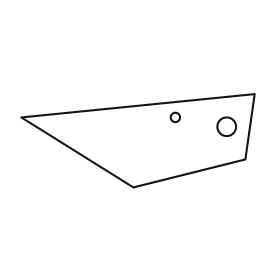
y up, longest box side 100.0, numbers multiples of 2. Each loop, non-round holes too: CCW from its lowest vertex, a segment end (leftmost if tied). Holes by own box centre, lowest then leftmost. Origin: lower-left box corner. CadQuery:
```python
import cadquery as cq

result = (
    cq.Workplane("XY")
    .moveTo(48.0, 0.0)
    .lineTo(96.0, 12.0)
    .lineTo(100.0, 40.0)
    .lineTo(0.0, 30.0)
    .close()
    .moveTo(88.0, 26.0)
    .circle(4.0)
    .moveTo(66.0, 30.0)
    .circle(2.0)
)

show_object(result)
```